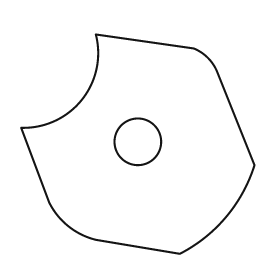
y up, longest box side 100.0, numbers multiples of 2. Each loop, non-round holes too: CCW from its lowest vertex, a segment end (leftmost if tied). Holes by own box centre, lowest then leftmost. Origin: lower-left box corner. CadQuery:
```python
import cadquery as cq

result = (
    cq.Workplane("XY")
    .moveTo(68.0, 0.0)
    .threePointArc((88.0, 16.0), (100.0, 38.0))
    .lineTo(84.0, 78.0)
    .threePointArc((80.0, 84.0), (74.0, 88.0))
    .lineTo(32.0, 94.0)
    .threePointArc((26.0, 66.0), (0.0, 54.0))
    .lineTo(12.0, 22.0)
    .threePointArc((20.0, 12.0), (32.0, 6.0))
    .close()
    .moveTo(50.0, 48.0)
    .circle(10.0)
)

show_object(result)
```